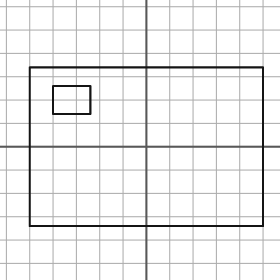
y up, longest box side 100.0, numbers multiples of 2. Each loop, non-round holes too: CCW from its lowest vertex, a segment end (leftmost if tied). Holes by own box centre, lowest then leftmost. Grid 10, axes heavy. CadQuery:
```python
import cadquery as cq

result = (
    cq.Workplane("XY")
    .moveTo(-50.0, -34.0)
    .lineTo(50.0, -34.0)
    .lineTo(50.0, 34.0)
    .lineTo(-50.0, 34.0)
    .close()
    .moveTo(-40.0, 14.0)
    .lineTo(-24.0, 14.0)
    .lineTo(-24.0, 26.0)
    .lineTo(-40.0, 26.0)
    .close()
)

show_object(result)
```